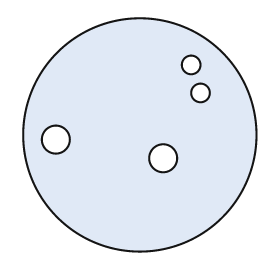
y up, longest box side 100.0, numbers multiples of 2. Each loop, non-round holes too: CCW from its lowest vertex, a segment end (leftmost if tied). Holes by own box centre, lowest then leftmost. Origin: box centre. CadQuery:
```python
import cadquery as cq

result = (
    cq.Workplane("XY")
    .moveTo(0.0, 0.0)
    .circle(50.0)
    .moveTo(10.0, -10.0)
    .circle(6.0)
    .moveTo(-36.0, -2.0)
    .circle(6.0)
    .moveTo(26.0, 18.0)
    .circle(4.0)
    .moveTo(22.0, 30.0)
    .circle(4.0)
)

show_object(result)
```